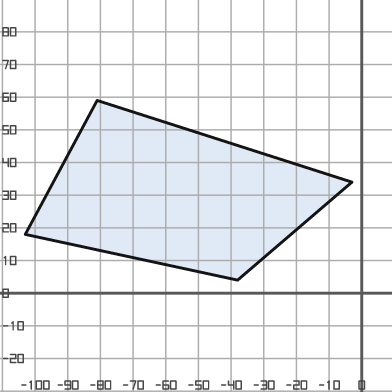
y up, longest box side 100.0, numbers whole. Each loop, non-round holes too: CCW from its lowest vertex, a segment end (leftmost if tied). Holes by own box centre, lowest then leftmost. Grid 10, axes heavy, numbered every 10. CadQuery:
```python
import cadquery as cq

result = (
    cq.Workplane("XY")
    .moveTo(-38.0, 4.0)
    .lineTo(-3.0, 34.0)
    .lineTo(-81.0, 59.0)
    .lineTo(-103.0, 18.0)
    .close()
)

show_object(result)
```